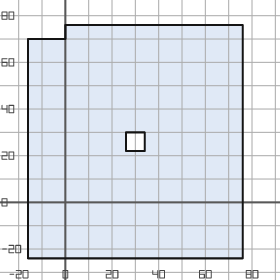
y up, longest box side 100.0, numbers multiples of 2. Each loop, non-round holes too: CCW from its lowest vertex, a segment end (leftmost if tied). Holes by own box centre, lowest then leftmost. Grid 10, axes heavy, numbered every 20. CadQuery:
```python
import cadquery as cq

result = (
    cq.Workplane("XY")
    .moveTo(-16.0, -24.0)
    .lineTo(76.0, -24.0)
    .lineTo(76.0, 76.0)
    .lineTo(0.0, 76.0)
    .lineTo(0.0, 70.0)
    .lineTo(-16.0, 70.0)
    .close()
    .moveTo(26.0, 22.0)
    .lineTo(34.0, 22.0)
    .lineTo(34.0, 30.0)
    .lineTo(26.0, 30.0)
    .close()
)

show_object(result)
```